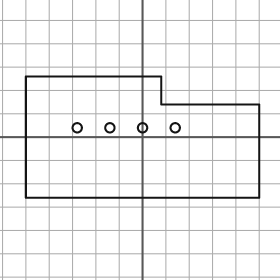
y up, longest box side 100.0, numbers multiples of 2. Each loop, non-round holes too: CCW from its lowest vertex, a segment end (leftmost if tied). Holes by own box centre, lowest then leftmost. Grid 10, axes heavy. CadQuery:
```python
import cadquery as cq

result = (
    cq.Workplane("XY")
    .moveTo(-50.0, -26.0)
    .lineTo(50.0, -26.0)
    .lineTo(50.0, 14.0)
    .lineTo(8.0, 14.0)
    .lineTo(8.0, 26.0)
    .lineTo(-50.0, 26.0)
    .close()
    .moveTo(-28.0, 4.0)
    .circle(2.0)
    .moveTo(-14.0, 4.0)
    .circle(2.0)
    .moveTo(0.0, 4.0)
    .circle(2.0)
    .moveTo(14.0, 4.0)
    .circle(2.0)
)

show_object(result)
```